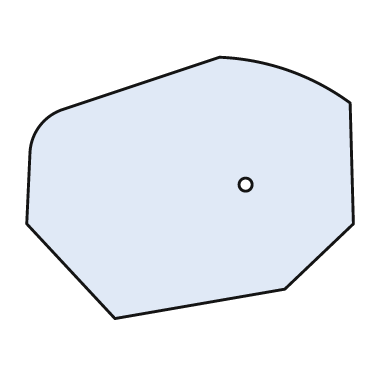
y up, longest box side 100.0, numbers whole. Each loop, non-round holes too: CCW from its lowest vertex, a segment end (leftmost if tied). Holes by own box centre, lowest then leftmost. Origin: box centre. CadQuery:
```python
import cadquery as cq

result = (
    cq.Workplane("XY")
    .moveTo(-23.0, -40.0)
    .lineTo(29.0, -31.0)
    .lineTo(50.0, -11.0)
    .lineTo(49.0, 26.0)
    .threePointArc((30.0, 36.0), (9.0, 40.0))
    .lineTo(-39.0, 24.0)
    .threePointArc((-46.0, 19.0), (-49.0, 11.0))
    .lineTo(-50.0, -11.0)
    .close()
    .moveTo(17.0, 1.0)
    .circle(2.0)
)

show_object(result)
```